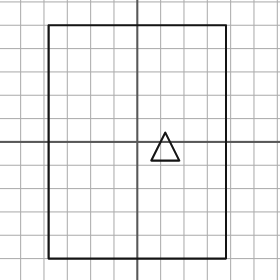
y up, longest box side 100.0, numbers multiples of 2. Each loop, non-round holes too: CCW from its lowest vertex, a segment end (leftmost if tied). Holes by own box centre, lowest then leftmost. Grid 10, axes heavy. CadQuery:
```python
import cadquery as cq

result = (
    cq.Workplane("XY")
    .moveTo(-38.0, -50.0)
    .lineTo(38.0, -50.0)
    .lineTo(38.0, 50.0)
    .lineTo(-38.0, 50.0)
    .close()
    .moveTo(6.0, -8.0)
    .lineTo(18.0, -8.0)
    .lineTo(12.0, 4.0)
    .close()
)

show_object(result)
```